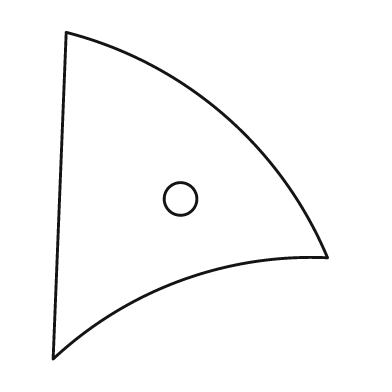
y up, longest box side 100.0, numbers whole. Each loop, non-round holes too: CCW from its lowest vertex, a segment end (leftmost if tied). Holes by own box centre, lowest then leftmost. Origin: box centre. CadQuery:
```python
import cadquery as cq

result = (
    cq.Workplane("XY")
    .moveTo(-42.0, -50.0)
    .threePointArc((-3.0, -26.0), (42.0, -19.0))
    .threePointArc((10.0, 25.0), (-38.0, 50.0))
    .close()
    .moveTo(-3.0, -1.0)
    .circle(5.0)
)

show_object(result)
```